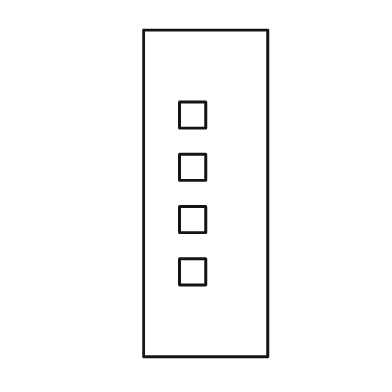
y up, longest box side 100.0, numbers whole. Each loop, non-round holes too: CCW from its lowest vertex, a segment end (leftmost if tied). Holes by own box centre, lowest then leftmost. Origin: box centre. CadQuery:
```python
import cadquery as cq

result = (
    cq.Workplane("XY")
    .moveTo(-19.0, -50.0)
    .lineTo(19.0, -50.0)
    .lineTo(19.0, 50.0)
    .lineTo(-19.0, 50.0)
    .close()
    .moveTo(-8.0, -28.0)
    .lineTo(0.0, -28.0)
    .lineTo(0.0, -20.0)
    .lineTo(-8.0, -20.0)
    .close()
    .moveTo(-8.0, -12.0)
    .lineTo(0.0, -12.0)
    .lineTo(0.0, -4.0)
    .lineTo(-8.0, -4.0)
    .close()
    .moveTo(-8.0, 4.0)
    .lineTo(0.0, 4.0)
    .lineTo(0.0, 12.0)
    .lineTo(-8.0, 12.0)
    .close()
    .moveTo(-8.0, 20.0)
    .lineTo(0.0, 20.0)
    .lineTo(0.0, 28.0)
    .lineTo(-8.0, 28.0)
    .close()
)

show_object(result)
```